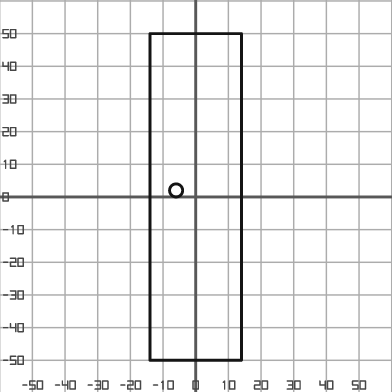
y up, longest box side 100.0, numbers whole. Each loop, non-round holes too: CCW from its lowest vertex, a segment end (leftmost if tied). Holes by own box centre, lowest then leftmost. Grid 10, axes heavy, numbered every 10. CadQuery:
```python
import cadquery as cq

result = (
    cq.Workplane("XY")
    .moveTo(-14.0, -50.0)
    .lineTo(14.0, -50.0)
    .lineTo(14.0, 50.0)
    .lineTo(-14.0, 50.0)
    .close()
    .moveTo(-6.0, 2.0)
    .circle(2.0)
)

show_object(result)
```